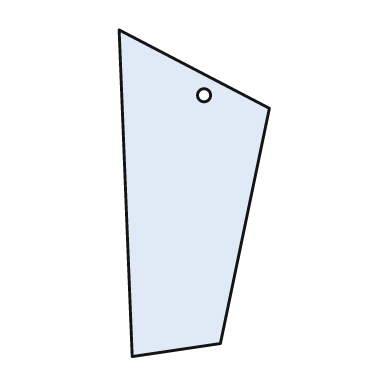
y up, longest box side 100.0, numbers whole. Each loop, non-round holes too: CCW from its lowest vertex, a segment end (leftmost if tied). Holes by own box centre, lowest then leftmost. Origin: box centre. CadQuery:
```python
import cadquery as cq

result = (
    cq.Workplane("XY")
    .moveTo(-19.0, -50.0)
    .lineTo(8.0, -46.0)
    .lineTo(23.0, 26.0)
    .lineTo(-23.0, 50.0)
    .close()
    .moveTo(3.0, 30.0)
    .circle(2.0)
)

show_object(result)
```